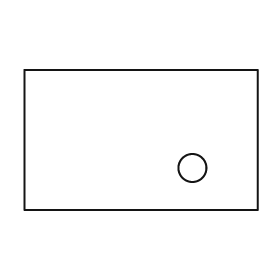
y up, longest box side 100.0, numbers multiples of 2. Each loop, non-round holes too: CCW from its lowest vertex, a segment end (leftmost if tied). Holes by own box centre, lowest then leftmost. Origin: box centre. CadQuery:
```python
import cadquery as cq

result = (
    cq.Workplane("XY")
    .moveTo(-50.0, -30.0)
    .lineTo(50.0, -30.0)
    .lineTo(50.0, 30.0)
    .lineTo(-50.0, 30.0)
    .close()
    .moveTo(22.0, -12.0)
    .circle(6.0)
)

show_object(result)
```